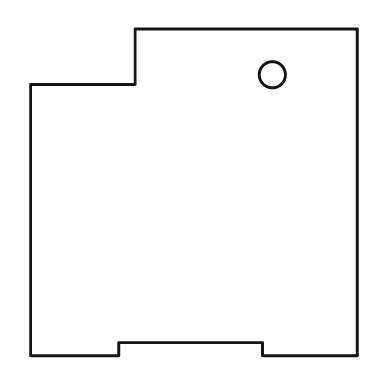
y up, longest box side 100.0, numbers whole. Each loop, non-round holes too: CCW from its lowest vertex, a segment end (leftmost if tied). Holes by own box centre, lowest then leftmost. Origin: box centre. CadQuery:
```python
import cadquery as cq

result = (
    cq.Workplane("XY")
    .moveTo(-50.0, -50.0)
    .lineTo(-23.0, -50.0)
    .lineTo(-23.0, -46.0)
    .lineTo(21.0, -46.0)
    .lineTo(21.0, -50.0)
    .lineTo(50.0, -50.0)
    .lineTo(50.0, 50.0)
    .lineTo(-18.0, 50.0)
    .lineTo(-18.0, 33.0)
    .lineTo(-50.0, 33.0)
    .close()
    .moveTo(24.0, 36.0)
    .circle(4.0)
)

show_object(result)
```